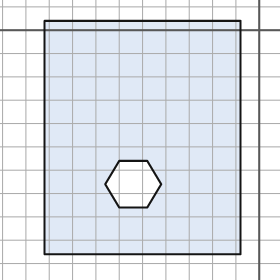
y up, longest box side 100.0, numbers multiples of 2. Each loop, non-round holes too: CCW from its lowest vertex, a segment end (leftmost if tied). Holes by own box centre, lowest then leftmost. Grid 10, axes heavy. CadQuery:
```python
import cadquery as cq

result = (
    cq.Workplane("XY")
    .moveTo(-92.0, -96.0)
    .lineTo(-8.0, -96.0)
    .lineTo(-8.0, 4.0)
    .lineTo(-92.0, 4.0)
    .close()
    .moveTo(-60.0, -76.0)
    .lineTo(-48.0, -76.0)
    .lineTo(-42.0, -66.0)
    .lineTo(-48.0, -56.0)
    .lineTo(-60.0, -56.0)
    .lineTo(-66.0, -66.0)
    .close()
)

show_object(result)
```